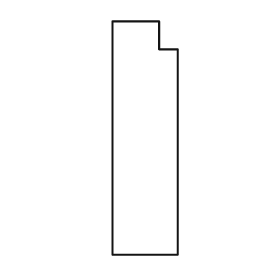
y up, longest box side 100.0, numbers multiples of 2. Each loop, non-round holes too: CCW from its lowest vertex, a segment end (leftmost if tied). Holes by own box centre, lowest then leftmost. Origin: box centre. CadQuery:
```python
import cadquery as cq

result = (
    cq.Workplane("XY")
    .moveTo(-14.0, -50.0)
    .lineTo(14.0, -50.0)
    .lineTo(14.0, 38.0)
    .lineTo(6.0, 38.0)
    .lineTo(6.0, 50.0)
    .lineTo(-14.0, 50.0)
    .close()
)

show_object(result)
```